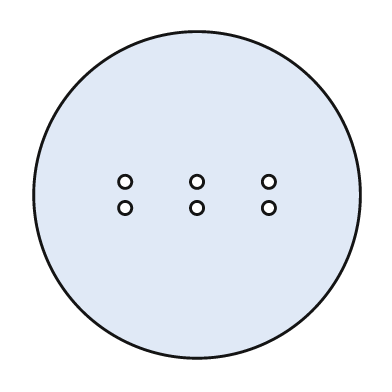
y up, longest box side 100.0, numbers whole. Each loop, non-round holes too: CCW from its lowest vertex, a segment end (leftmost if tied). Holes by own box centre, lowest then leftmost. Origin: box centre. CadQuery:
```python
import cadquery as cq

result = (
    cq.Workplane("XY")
    .moveTo(0.0, 0.0)
    .circle(50.0)
    .moveTo(-22.0, -4.0)
    .circle(2.0)
    .moveTo(0.0, -4.0)
    .circle(2.0)
    .moveTo(22.0, -4.0)
    .circle(2.0)
    .moveTo(-22.0, 4.0)
    .circle(2.0)
    .moveTo(0.0, 4.0)
    .circle(2.0)
    .moveTo(22.0, 4.0)
    .circle(2.0)
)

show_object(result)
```